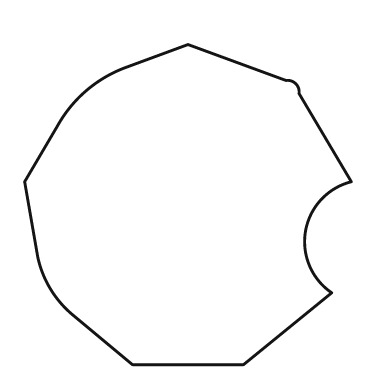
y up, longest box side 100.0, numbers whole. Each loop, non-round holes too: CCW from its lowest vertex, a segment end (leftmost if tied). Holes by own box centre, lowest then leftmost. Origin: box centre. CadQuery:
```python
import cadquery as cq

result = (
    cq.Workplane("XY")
    .moveTo(-17.0, -49.0)
    .lineTo(17.0, -49.0)
    .lineTo(44.0, -27.0)
    .threePointArc((36.0, -8.0), (50.0, 7.0))
    .lineTo(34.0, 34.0)
    .threePointArc((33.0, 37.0), (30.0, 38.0))
    .lineTo(0.0, 49.0)
    .lineTo(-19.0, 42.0)
    .threePointArc((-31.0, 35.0), (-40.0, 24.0))
    .lineTo(-50.0, 7.0)
    .lineTo(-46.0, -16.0)
    .threePointArc((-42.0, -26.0), (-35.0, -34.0))
    .close()
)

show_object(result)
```